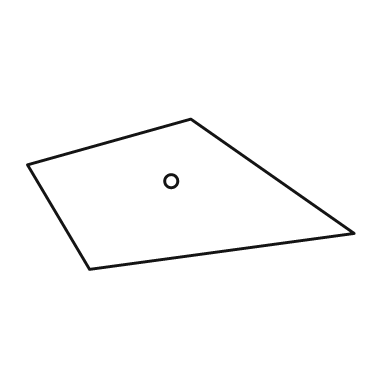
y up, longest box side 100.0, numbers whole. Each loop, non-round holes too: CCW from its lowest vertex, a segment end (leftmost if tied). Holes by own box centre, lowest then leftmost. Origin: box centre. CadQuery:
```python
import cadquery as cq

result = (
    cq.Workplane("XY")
    .moveTo(-31.0, -23.0)
    .lineTo(50.0, -12.0)
    .lineTo(0.0, 23.0)
    .lineTo(-50.0, 9.0)
    .close()
    .moveTo(-6.0, 4.0)
    .circle(2.0)
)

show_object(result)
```